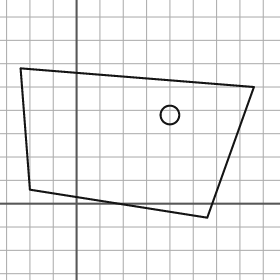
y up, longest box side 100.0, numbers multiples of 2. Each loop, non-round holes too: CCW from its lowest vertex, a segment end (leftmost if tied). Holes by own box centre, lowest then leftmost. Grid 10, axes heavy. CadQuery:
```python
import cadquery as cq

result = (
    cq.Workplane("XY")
    .moveTo(56.0, -6.0)
    .lineTo(76.0, 50.0)
    .lineTo(-24.0, 58.0)
    .lineTo(-20.0, 6.0)
    .close()
    .moveTo(40.0, 38.0)
    .circle(4.0)
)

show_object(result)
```